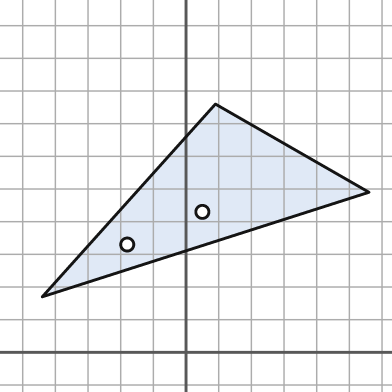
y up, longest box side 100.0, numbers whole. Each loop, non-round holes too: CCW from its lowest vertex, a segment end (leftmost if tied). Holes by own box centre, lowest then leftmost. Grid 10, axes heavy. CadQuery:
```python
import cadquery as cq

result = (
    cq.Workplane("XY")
    .moveTo(-44.0, 17.0)
    .lineTo(56.0, 49.0)
    .lineTo(9.0, 76.0)
    .close()
    .moveTo(-18.0, 33.0)
    .circle(2.0)
    .moveTo(5.0, 43.0)
    .circle(2.0)
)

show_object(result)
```